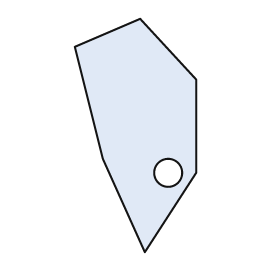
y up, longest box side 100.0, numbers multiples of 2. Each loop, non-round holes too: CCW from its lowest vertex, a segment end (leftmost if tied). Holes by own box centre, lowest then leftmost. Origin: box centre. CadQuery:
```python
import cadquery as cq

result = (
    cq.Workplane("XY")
    .moveTo(4.0, -50.0)
    .lineTo(26.0, -16.0)
    .lineTo(26.0, 24.0)
    .lineTo(2.0, 50.0)
    .lineTo(-26.0, 38.0)
    .lineTo(-14.0, -10.0)
    .close()
    .moveTo(14.0, -16.0)
    .circle(6.0)
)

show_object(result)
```